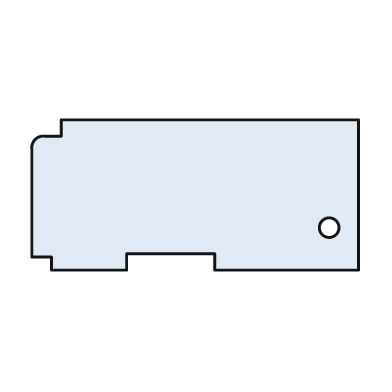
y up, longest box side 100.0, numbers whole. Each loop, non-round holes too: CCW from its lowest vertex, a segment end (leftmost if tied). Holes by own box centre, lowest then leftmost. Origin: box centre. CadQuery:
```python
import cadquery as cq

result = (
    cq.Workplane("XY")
    .moveTo(-44.0, -23.0)
    .lineTo(-21.0, -23.0)
    .lineTo(-21.0, -18.0)
    .lineTo(6.0, -18.0)
    .lineTo(6.0, -23.0)
    .lineTo(50.0, -23.0)
    .lineTo(50.0, 23.0)
    .lineTo(-41.0, 23.0)
    .lineTo(-41.0, 18.0)
    .lineTo(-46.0, 18.0)
    .threePointArc((-49.0, 17.0), (-50.0, 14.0))
    .lineTo(-50.0, -19.0)
    .lineTo(-44.0, -19.0)
    .close()
    .moveTo(41.0, -10.0)
    .circle(3.0)
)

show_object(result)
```